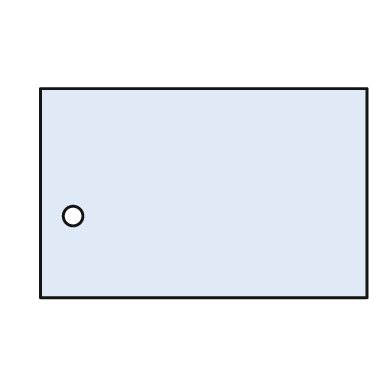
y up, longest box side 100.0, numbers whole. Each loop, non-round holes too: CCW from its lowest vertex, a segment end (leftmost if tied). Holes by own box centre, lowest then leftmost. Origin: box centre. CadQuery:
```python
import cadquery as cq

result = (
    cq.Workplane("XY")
    .moveTo(-50.0, -32.0)
    .lineTo(50.0, -32.0)
    .lineTo(50.0, 32.0)
    .lineTo(-50.0, 32.0)
    .close()
    .moveTo(-40.0, -7.0)
    .circle(3.0)
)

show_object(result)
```